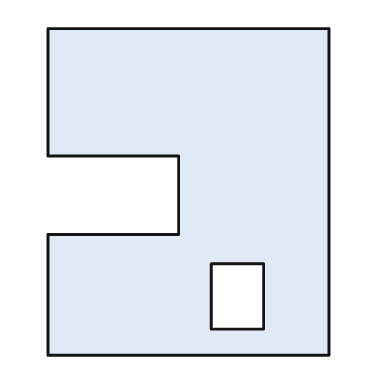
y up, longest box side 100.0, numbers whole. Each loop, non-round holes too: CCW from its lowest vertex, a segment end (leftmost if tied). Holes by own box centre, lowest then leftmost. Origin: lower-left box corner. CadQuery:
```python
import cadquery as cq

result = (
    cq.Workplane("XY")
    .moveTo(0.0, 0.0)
    .lineTo(86.0, 0.0)
    .lineTo(86.0, 100.0)
    .lineTo(0.0, 100.0)
    .lineTo(0.0, 61.0)
    .lineTo(40.0, 61.0)
    .lineTo(40.0, 37.0)
    .lineTo(0.0, 37.0)
    .close()
    .moveTo(50.0, 8.0)
    .lineTo(66.0, 8.0)
    .lineTo(66.0, 28.0)
    .lineTo(50.0, 28.0)
    .close()
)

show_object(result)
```